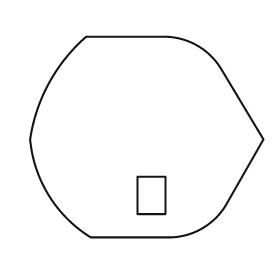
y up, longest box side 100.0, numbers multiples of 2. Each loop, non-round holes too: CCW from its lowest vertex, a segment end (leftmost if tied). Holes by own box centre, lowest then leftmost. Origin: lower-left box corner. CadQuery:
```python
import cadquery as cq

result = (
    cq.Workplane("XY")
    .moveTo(26.0, 0.0)
    .lineTo(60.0, 0.0)
    .threePointArc((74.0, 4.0), (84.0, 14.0))
    .lineTo(100.0, 42.0)
    .lineTo(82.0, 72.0)
    .threePointArc((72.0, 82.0), (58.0, 86.0))
    .lineTo(24.0, 86.0)
    .threePointArc((8.0, 66.0), (0.0, 42.0))
    .threePointArc((8.0, 18.0), (26.0, 0.0))
    .close()
    .moveTo(46.0, 10.0)
    .lineTo(58.0, 10.0)
    .lineTo(58.0, 26.0)
    .lineTo(46.0, 26.0)
    .close()
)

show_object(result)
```